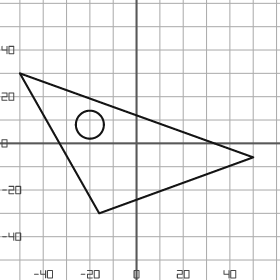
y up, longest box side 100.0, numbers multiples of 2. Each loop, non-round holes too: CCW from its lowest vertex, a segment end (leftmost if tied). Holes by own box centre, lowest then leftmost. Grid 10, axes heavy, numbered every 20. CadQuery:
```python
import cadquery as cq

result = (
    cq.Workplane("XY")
    .moveTo(-16.0, -30.0)
    .lineTo(50.0, -6.0)
    .lineTo(-50.0, 30.0)
    .close()
    .moveTo(-20.0, 8.0)
    .circle(6.0)
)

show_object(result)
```